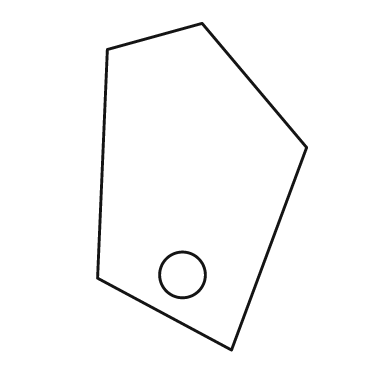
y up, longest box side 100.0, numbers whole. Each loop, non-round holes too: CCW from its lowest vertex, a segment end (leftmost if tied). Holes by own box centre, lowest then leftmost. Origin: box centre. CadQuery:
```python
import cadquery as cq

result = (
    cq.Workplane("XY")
    .moveTo(9.0, -50.0)
    .lineTo(32.0, 12.0)
    .lineTo(0.0, 50.0)
    .lineTo(-29.0, 42.0)
    .lineTo(-32.0, -28.0)
    .close()
    .moveTo(-6.0, -27.0)
    .circle(7.0)
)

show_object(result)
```